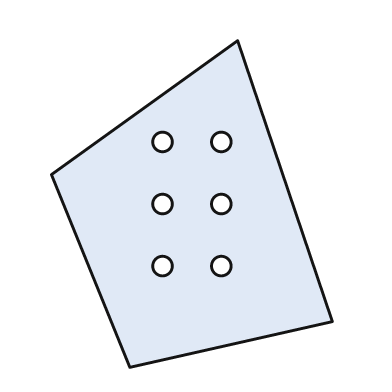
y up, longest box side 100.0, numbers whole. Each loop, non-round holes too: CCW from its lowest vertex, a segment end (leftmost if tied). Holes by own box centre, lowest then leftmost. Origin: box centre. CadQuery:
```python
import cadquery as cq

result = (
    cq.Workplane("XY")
    .moveTo(-19.0, -50.0)
    .lineTo(43.0, -36.0)
    .lineTo(14.0, 50.0)
    .lineTo(-43.0, 9.0)
    .close()
    .moveTo(-9.0, -19.0)
    .circle(3.0)
    .moveTo(9.0, -19.0)
    .circle(3.0)
    .moveTo(-9.0, 0.0)
    .circle(3.0)
    .moveTo(9.0, 0.0)
    .circle(3.0)
    .moveTo(-9.0, 19.0)
    .circle(3.0)
    .moveTo(9.0, 19.0)
    .circle(3.0)
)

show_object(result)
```